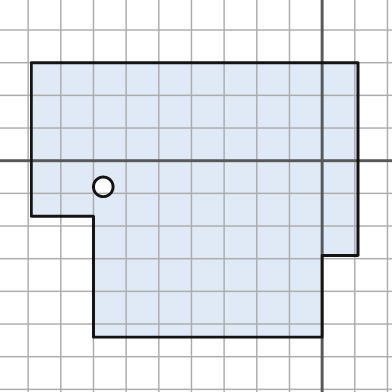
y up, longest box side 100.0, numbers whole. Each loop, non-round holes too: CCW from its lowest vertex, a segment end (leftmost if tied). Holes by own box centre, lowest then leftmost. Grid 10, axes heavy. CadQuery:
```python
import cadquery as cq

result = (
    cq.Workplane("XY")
    .moveTo(-70.0, -54.0)
    .lineTo(0.0, -54.0)
    .lineTo(0.0, -29.0)
    .lineTo(11.0, -29.0)
    .lineTo(11.0, 30.0)
    .lineTo(-89.0, 30.0)
    .lineTo(-89.0, -17.0)
    .lineTo(-70.0, -17.0)
    .close()
    .moveTo(-67.0, -8.0)
    .circle(3.0)
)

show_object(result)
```